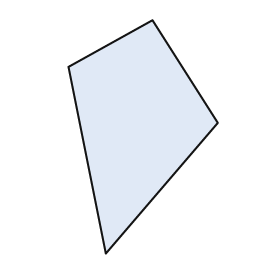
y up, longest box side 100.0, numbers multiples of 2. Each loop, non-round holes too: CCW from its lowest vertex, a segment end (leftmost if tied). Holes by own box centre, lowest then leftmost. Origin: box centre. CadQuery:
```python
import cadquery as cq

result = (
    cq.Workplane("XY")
    .moveTo(-16.0, -50.0)
    .lineTo(32.0, 6.0)
    .lineTo(4.0, 50.0)
    .lineTo(-32.0, 30.0)
    .close()
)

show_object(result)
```